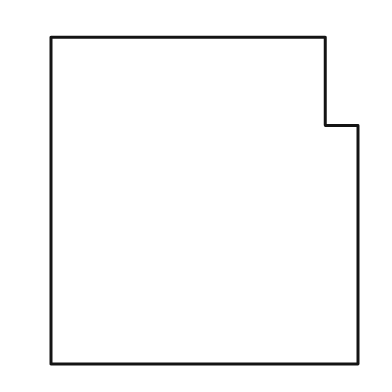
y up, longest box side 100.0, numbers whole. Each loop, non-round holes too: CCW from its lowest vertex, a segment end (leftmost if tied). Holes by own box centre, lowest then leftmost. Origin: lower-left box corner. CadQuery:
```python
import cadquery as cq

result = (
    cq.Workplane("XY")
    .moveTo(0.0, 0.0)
    .lineTo(94.0, 0.0)
    .lineTo(94.0, 73.0)
    .lineTo(84.0, 73.0)
    .lineTo(84.0, 100.0)
    .lineTo(0.0, 100.0)
    .close()
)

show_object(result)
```